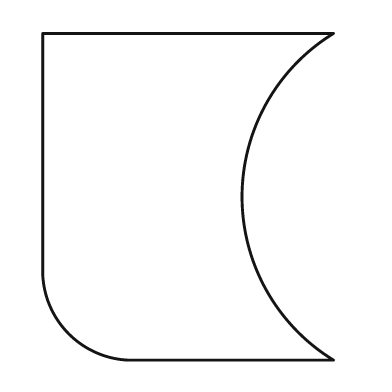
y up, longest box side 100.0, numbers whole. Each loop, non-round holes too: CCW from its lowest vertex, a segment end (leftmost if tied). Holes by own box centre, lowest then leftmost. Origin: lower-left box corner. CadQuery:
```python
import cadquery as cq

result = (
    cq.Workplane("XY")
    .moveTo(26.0, 0.0)
    .lineTo(89.0, 0.0)
    .threePointArc((61.0, 50.0), (89.0, 100.0))
    .lineTo(0.0, 100.0)
    .lineTo(0.0, 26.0)
    .threePointArc((8.0, 8.0), (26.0, 0.0))
    .close()
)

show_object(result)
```